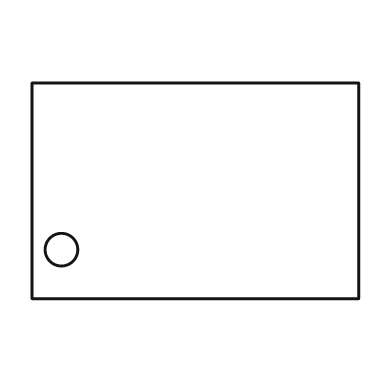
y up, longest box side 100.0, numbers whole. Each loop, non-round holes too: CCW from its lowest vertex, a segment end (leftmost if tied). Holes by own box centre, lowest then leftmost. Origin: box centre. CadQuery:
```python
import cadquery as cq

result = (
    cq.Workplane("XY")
    .moveTo(-50.0, -33.0)
    .lineTo(50.0, -33.0)
    .lineTo(50.0, 33.0)
    .lineTo(-50.0, 33.0)
    .close()
    .moveTo(-41.0, -18.0)
    .circle(5.0)
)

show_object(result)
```